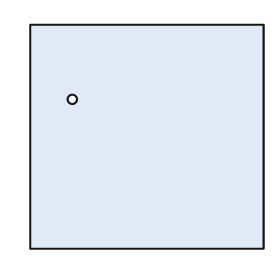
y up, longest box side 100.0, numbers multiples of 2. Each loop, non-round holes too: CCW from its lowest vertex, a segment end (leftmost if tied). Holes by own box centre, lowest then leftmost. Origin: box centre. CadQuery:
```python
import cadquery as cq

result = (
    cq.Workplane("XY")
    .moveTo(-50.0, -48.0)
    .lineTo(50.0, -48.0)
    .lineTo(50.0, 48.0)
    .lineTo(-50.0, 48.0)
    .close()
    .moveTo(-32.0, 16.0)
    .circle(2.0)
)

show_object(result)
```